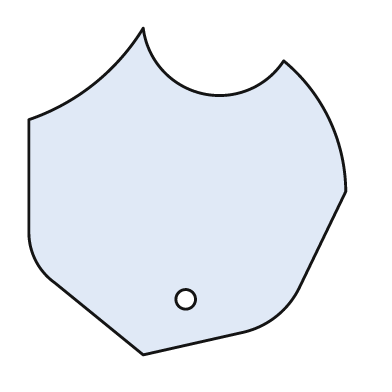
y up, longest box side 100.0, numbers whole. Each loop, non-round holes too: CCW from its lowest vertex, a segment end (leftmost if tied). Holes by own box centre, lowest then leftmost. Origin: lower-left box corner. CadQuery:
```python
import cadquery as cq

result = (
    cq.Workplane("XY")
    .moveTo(35.0, 0.0)
    .lineTo(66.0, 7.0)
    .threePointArc((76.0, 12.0), (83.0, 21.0))
    .lineTo(97.0, 50.0)
    .threePointArc((92.0, 72.0), (78.0, 90.0))
    .threePointArc((53.0, 80.0), (35.0, 100.0))
    .threePointArc((20.0, 83.0), (0.0, 72.0))
    .lineTo(0.0, 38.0)
    .threePointArc((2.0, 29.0), (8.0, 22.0))
    .close()
    .moveTo(48.0, 17.0)
    .circle(3.0)
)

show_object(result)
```